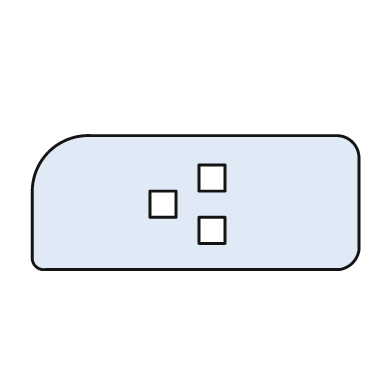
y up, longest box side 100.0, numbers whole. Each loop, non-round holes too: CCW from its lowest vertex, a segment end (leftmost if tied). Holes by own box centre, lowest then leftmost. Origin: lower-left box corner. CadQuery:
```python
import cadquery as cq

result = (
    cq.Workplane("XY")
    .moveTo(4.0, 0.0)
    .lineTo(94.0, 0.0)
    .threePointArc((98.0, 2.0), (100.0, 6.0))
    .lineTo(100.0, 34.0)
    .threePointArc((98.0, 39.0), (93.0, 41.0))
    .lineTo(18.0, 41.0)
    .threePointArc((5.0, 36.0), (0.0, 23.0))
    .lineTo(0.0, 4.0)
    .threePointArc((1.0, 1.0), (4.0, 0.0))
    .close()
    .moveTo(51.0, 8.0)
    .lineTo(59.0, 8.0)
    .lineTo(59.0, 16.0)
    .lineTo(51.0, 16.0)
    .close()
    .moveTo(36.0, 16.0)
    .lineTo(44.0, 16.0)
    .lineTo(44.0, 24.0)
    .lineTo(36.0, 24.0)
    .close()
    .moveTo(51.0, 24.0)
    .lineTo(59.0, 24.0)
    .lineTo(59.0, 32.0)
    .lineTo(51.0, 32.0)
    .close()
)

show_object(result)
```